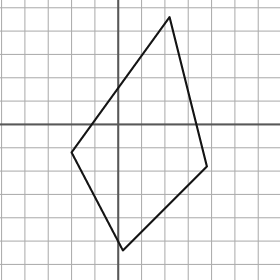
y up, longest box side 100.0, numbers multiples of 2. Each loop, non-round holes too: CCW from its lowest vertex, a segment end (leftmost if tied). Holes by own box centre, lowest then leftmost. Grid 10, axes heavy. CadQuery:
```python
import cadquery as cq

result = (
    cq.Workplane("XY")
    .moveTo(2.0, -54.0)
    .lineTo(38.0, -18.0)
    .lineTo(22.0, 46.0)
    .lineTo(-20.0, -12.0)
    .close()
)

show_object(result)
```